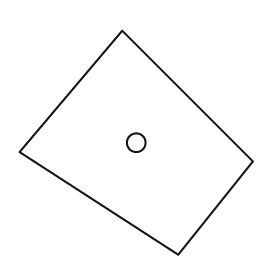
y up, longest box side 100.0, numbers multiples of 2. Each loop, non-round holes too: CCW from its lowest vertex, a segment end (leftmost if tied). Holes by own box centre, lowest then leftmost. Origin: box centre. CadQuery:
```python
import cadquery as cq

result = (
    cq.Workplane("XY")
    .moveTo(18.0, -48.0)
    .lineTo(50.0, -8.0)
    .lineTo(-6.0, 48.0)
    .lineTo(-50.0, -4.0)
    .close()
    .moveTo(0.0, 0.0)
    .circle(4.0)
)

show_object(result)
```